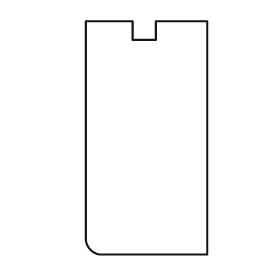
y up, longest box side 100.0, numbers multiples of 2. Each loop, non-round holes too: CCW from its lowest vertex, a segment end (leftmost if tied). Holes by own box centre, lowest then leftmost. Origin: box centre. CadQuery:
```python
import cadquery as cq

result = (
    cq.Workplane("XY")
    .moveTo(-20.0, -50.0)
    .lineTo(26.0, -50.0)
    .lineTo(26.0, 50.0)
    .lineTo(4.0, 50.0)
    .lineTo(4.0, 42.0)
    .lineTo(-6.0, 42.0)
    .lineTo(-6.0, 50.0)
    .lineTo(-26.0, 50.0)
    .lineTo(-26.0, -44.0)
    .threePointArc((-24.0, -48.0), (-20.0, -50.0))
    .close()
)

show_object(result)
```